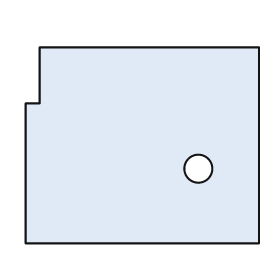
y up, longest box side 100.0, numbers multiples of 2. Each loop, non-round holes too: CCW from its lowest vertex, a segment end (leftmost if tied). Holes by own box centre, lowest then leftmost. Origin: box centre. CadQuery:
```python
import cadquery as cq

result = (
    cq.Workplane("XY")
    .moveTo(-50.0, -42.0)
    .lineTo(50.0, -42.0)
    .lineTo(50.0, 42.0)
    .lineTo(-44.0, 42.0)
    .lineTo(-44.0, 18.0)
    .lineTo(-50.0, 18.0)
    .close()
    .moveTo(24.0, -10.0)
    .circle(6.0)
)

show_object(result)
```